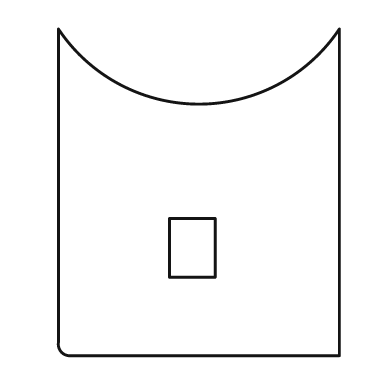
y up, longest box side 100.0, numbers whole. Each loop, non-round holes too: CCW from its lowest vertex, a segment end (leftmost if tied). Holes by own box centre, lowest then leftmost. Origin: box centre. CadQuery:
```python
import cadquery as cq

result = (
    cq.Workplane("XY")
    .moveTo(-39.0, -50.0)
    .lineTo(43.0, -50.0)
    .lineTo(43.0, 50.0)
    .threePointArc((0.0, 27.0), (-43.0, 50.0))
    .lineTo(-43.0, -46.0)
    .threePointArc((-42.0, -49.0), (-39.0, -50.0))
    .close()
    .moveTo(-9.0, -26.0)
    .lineTo(5.0, -26.0)
    .lineTo(5.0, -8.0)
    .lineTo(-9.0, -8.0)
    .close()
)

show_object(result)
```